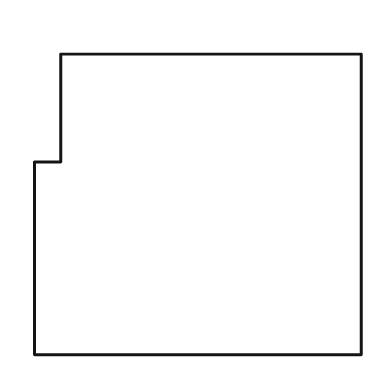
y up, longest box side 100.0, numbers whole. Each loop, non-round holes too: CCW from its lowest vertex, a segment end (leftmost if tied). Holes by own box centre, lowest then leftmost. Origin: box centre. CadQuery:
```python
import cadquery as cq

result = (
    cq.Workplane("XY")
    .moveTo(-50.0, -46.0)
    .lineTo(50.0, -46.0)
    .lineTo(50.0, 46.0)
    .lineTo(-42.0, 46.0)
    .lineTo(-42.0, 13.0)
    .lineTo(-50.0, 13.0)
    .close()
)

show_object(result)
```